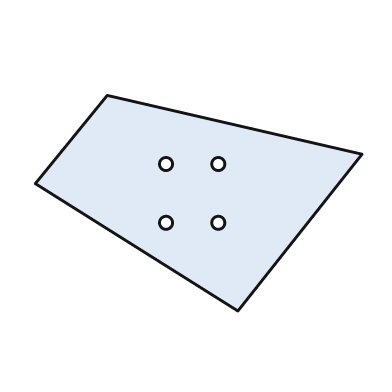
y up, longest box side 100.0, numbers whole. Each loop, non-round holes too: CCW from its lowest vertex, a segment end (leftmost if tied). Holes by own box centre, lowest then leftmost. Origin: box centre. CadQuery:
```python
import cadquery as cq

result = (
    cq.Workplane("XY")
    .moveTo(12.0, -33.0)
    .lineTo(50.0, 15.0)
    .lineTo(-28.0, 33.0)
    .lineTo(-50.0, 6.0)
    .close()
    .moveTo(-10.0, -6.0)
    .circle(2.0)
    .moveTo(6.0, -6.0)
    .circle(2.0)
    .moveTo(-10.0, 12.0)
    .circle(2.0)
    .moveTo(6.0, 12.0)
    .circle(2.0)
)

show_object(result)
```